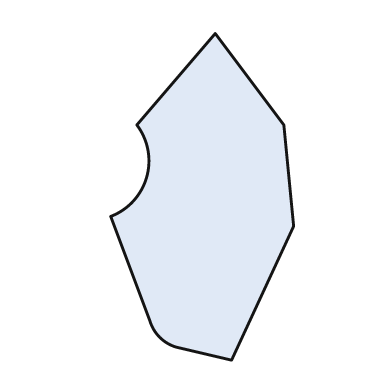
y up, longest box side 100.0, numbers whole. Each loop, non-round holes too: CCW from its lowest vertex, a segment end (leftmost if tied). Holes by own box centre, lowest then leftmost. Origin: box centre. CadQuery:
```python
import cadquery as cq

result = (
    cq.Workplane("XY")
    .moveTo(9.0, -50.0)
    .lineTo(28.0, -9.0)
    .lineTo(25.0, 22.0)
    .lineTo(4.0, 50.0)
    .lineTo(-20.0, 22.0)
    .threePointArc((-17.0, 6.0), (-28.0, -6.0))
    .lineTo(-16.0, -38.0)
    .threePointArc((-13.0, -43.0), (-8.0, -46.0))
    .close()
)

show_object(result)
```